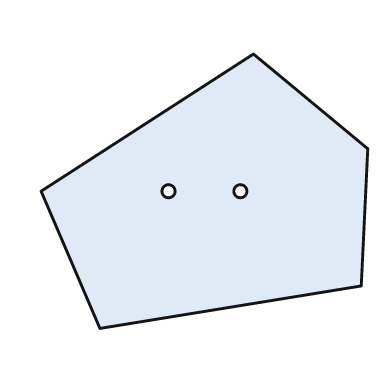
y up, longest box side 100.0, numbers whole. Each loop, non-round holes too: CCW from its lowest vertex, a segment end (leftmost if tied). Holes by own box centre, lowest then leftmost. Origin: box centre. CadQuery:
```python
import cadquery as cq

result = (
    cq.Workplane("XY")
    .moveTo(-32.0, -42.0)
    .lineTo(48.0, -29.0)
    .lineTo(50.0, 13.0)
    .lineTo(15.0, 42.0)
    .lineTo(-50.0, 0.0)
    .close()
    .moveTo(-11.0, 0.0)
    .circle(2.0)
    .moveTo(11.0, 0.0)
    .circle(2.0)
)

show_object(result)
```